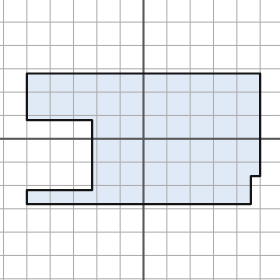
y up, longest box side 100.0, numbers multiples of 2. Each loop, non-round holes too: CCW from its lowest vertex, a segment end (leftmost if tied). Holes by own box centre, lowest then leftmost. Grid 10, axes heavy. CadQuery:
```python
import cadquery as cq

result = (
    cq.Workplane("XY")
    .moveTo(-50.0, -28.0)
    .lineTo(46.0, -28.0)
    .lineTo(46.0, -16.0)
    .lineTo(50.0, -16.0)
    .lineTo(50.0, 28.0)
    .lineTo(-50.0, 28.0)
    .lineTo(-50.0, 8.0)
    .lineTo(-22.0, 8.0)
    .lineTo(-22.0, -22.0)
    .lineTo(-50.0, -22.0)
    .close()
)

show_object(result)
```